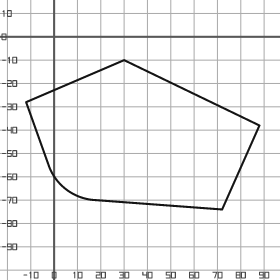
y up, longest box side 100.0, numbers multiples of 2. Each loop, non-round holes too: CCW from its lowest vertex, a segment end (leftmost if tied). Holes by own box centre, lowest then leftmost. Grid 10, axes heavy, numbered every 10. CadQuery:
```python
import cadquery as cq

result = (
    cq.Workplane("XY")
    .moveTo(72.0, -74.0)
    .lineTo(88.0, -38.0)
    .lineTo(30.0, -10.0)
    .lineTo(-12.0, -28.0)
    .lineTo(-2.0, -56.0)
    .threePointArc((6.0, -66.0), (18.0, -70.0))
    .close()
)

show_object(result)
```